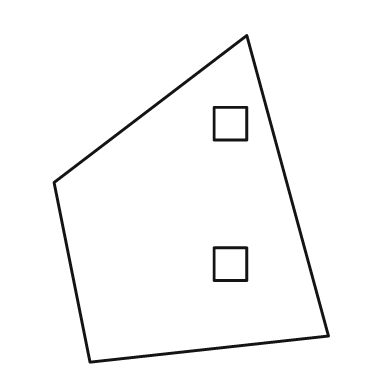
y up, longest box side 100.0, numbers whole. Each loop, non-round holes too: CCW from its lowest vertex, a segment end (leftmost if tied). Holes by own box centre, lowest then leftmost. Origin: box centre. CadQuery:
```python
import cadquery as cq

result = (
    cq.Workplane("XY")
    .moveTo(-31.0, -50.0)
    .lineTo(42.0, -42.0)
    .lineTo(17.0, 50.0)
    .lineTo(-42.0, 5.0)
    .close()
    .moveTo(7.0, -25.0)
    .lineTo(17.0, -25.0)
    .lineTo(17.0, -15.0)
    .lineTo(7.0, -15.0)
    .close()
    .moveTo(7.0, 18.0)
    .lineTo(17.0, 18.0)
    .lineTo(17.0, 28.0)
    .lineTo(7.0, 28.0)
    .close()
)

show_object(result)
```